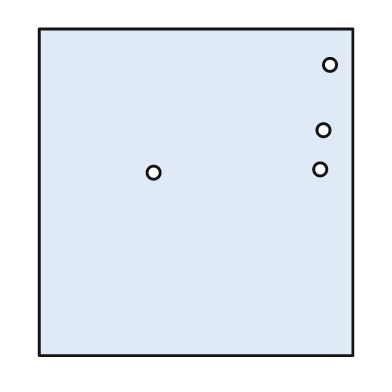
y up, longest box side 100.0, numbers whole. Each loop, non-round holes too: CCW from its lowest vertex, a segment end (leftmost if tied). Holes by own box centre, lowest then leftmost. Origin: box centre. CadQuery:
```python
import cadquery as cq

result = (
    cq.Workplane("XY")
    .moveTo(-48.0, -50.0)
    .lineTo(48.0, -50.0)
    .lineTo(48.0, 50.0)
    .lineTo(-48.0, 50.0)
    .close()
    .moveTo(-13.0, 6.0)
    .circle(2.0)
    .moveTo(38.0, 7.0)
    .circle(2.0)
    .moveTo(39.0, 19.0)
    .circle(2.0)
    .moveTo(41.0, 39.0)
    .circle(2.0)
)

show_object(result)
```